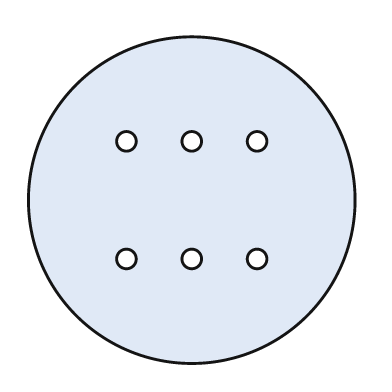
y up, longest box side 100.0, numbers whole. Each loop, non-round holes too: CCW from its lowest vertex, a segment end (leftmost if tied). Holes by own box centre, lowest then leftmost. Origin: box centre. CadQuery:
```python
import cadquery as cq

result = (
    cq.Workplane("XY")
    .moveTo(0.0, 0.0)
    .circle(50.0)
    .moveTo(-20.0, -18.0)
    .circle(3.0)
    .moveTo(0.0, -18.0)
    .circle(3.0)
    .moveTo(20.0, -18.0)
    .circle(3.0)
    .moveTo(-20.0, 18.0)
    .circle(3.0)
    .moveTo(0.0, 18.0)
    .circle(3.0)
    .moveTo(20.0, 18.0)
    .circle(3.0)
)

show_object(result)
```